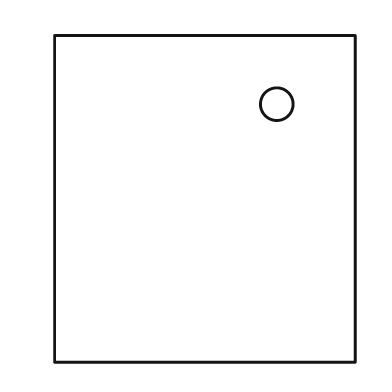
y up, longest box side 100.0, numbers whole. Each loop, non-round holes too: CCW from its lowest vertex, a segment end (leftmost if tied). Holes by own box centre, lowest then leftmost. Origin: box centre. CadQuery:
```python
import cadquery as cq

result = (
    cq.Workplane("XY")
    .moveTo(-46.0, -50.0)
    .lineTo(46.0, -50.0)
    .lineTo(46.0, 50.0)
    .lineTo(-46.0, 50.0)
    .close()
    .moveTo(22.0, 29.0)
    .circle(5.0)
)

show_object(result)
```